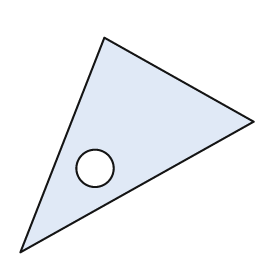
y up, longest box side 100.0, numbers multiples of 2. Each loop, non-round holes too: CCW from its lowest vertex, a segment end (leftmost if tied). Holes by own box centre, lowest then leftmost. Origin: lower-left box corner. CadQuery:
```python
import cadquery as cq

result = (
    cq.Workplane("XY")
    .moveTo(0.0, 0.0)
    .lineTo(100.0, 56.0)
    .lineTo(36.0, 92.0)
    .close()
    .moveTo(32.0, 36.0)
    .circle(8.0)
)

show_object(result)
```